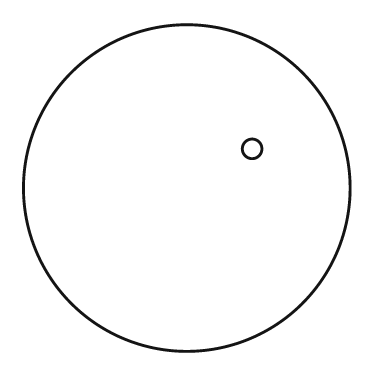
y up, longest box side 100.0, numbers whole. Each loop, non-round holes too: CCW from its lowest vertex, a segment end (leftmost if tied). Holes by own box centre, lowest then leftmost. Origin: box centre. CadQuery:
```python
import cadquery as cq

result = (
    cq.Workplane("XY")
    .moveTo(0.0, 0.0)
    .circle(50.0)
    .moveTo(20.0, 12.0)
    .circle(3.0)
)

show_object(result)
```